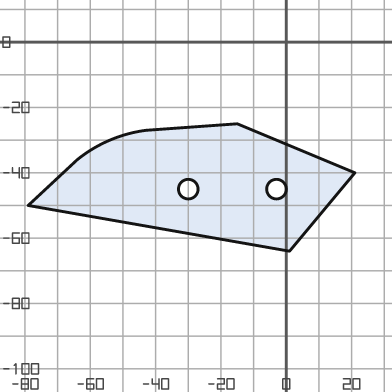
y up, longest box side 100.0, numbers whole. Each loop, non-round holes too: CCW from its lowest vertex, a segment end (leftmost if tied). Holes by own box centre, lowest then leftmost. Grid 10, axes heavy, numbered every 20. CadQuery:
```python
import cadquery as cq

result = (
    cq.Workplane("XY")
    .moveTo(1.0, -64.0)
    .lineTo(21.0, -40.0)
    .lineTo(-15.0, -25.0)
    .lineTo(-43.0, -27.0)
    .threePointArc((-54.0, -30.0), (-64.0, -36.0))
    .lineTo(-79.0, -50.0)
    .close()
    .moveTo(-30.0, -45.0)
    .circle(3.0)
    .moveTo(-3.0, -45.0)
    .circle(3.0)
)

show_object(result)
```